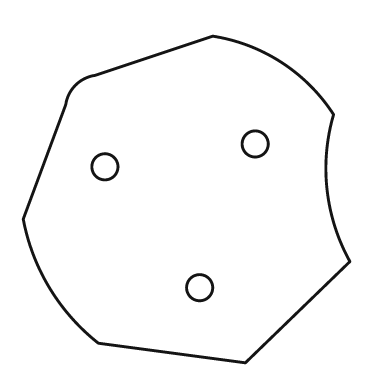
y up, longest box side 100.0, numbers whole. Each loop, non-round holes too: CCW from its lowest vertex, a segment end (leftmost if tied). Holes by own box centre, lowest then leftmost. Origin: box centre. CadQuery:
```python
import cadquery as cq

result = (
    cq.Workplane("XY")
    .moveTo(18.0, -50.0)
    .lineTo(50.0, -19.0)
    .threePointArc((43.0, 3.0), (45.0, 26.0))
    .threePointArc((29.0, 42.0), (8.0, 50.0))
    .lineTo(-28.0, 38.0)
    .threePointArc((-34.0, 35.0), (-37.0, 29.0))
    .lineTo(-50.0, -6.0)
    .threePointArc((-42.0, -27.0), (-27.0, -44.0))
    .close()
    .moveTo(4.0, -27.0)
    .circle(4.0)
    .moveTo(-25.0, 10.0)
    .circle(4.0)
    .moveTo(21.0, 17.0)
    .circle(4.0)
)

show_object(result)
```